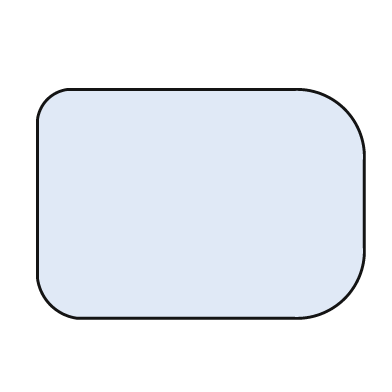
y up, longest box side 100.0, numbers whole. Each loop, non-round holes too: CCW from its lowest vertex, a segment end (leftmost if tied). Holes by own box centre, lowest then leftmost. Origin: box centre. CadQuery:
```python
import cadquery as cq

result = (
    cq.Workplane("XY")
    .moveTo(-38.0, -35.0)
    .lineTo(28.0, -35.0)
    .threePointArc((44.0, -29.0), (50.0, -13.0))
    .lineTo(50.0, 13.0)
    .threePointArc((44.0, 29.0), (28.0, 35.0))
    .lineTo(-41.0, 35.0)
    .threePointArc((-47.0, 32.0), (-50.0, 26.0))
    .lineTo(-50.0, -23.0)
    .threePointArc((-46.0, -31.0), (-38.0, -35.0))
    .close()
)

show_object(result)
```